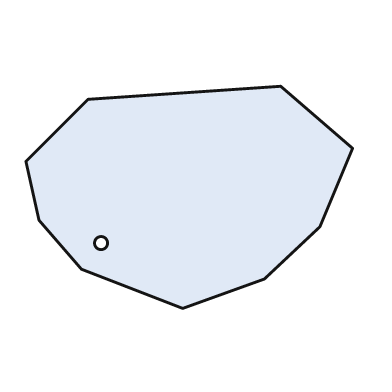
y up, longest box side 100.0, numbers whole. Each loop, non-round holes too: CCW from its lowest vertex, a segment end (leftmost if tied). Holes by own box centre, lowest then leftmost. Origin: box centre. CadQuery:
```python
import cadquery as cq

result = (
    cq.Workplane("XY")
    .moveTo(-2.0, -34.0)
    .lineTo(23.0, -25.0)
    .lineTo(40.0, -9.0)
    .lineTo(50.0, 15.0)
    .lineTo(28.0, 34.0)
    .lineTo(-31.0, 30.0)
    .lineTo(-50.0, 11.0)
    .lineTo(-46.0, -7.0)
    .lineTo(-33.0, -22.0)
    .close()
    .moveTo(-27.0, -14.0)
    .circle(2.0)
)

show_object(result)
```